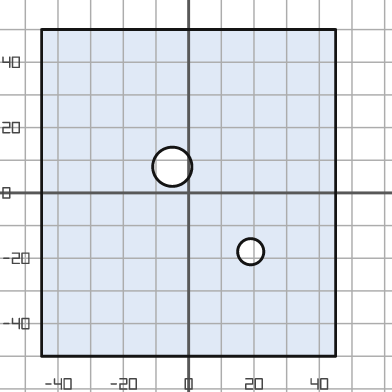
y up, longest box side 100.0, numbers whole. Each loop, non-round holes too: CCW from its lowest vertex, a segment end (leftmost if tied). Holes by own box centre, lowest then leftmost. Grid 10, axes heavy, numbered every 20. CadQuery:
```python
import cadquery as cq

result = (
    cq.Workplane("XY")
    .moveTo(-45.0, -50.0)
    .lineTo(45.0, -50.0)
    .lineTo(45.0, 50.0)
    .lineTo(-45.0, 50.0)
    .close()
    .moveTo(19.0, -18.0)
    .circle(4.0)
    .moveTo(-5.0, 8.0)
    .circle(6.0)
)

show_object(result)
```